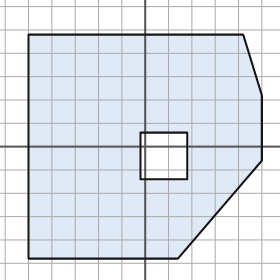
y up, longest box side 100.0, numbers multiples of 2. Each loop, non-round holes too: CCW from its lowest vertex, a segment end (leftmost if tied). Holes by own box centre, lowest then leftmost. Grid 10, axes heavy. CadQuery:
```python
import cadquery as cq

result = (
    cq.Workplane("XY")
    .moveTo(-50.0, -48.0)
    .lineTo(14.0, -48.0)
    .lineTo(50.0, -6.0)
    .lineTo(50.0, 22.0)
    .lineTo(42.0, 48.0)
    .lineTo(-50.0, 48.0)
    .close()
    .moveTo(-2.0, -14.0)
    .lineTo(18.0, -14.0)
    .lineTo(18.0, 6.0)
    .lineTo(-2.0, 6.0)
    .close()
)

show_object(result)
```